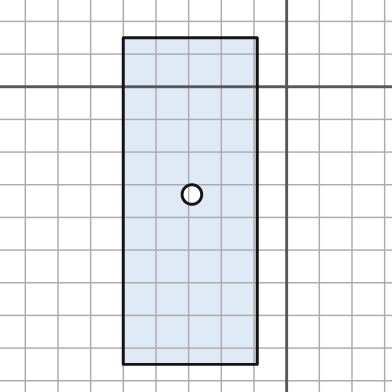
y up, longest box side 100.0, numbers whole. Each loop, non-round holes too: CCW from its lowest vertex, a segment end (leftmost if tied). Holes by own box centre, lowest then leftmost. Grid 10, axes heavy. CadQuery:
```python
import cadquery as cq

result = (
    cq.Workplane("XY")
    .moveTo(-50.0, -85.0)
    .lineTo(-9.0, -85.0)
    .lineTo(-9.0, 15.0)
    .lineTo(-50.0, 15.0)
    .close()
    .moveTo(-29.0, -33.0)
    .circle(3.0)
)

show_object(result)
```